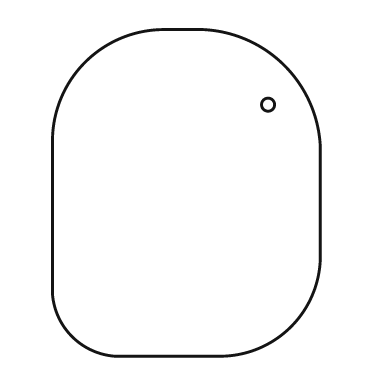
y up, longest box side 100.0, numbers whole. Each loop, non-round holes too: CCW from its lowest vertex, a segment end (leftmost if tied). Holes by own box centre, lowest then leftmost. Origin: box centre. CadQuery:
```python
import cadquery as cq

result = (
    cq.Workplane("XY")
    .moveTo(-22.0, -50.0)
    .lineTo(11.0, -50.0)
    .threePointArc((32.0, -41.0), (41.0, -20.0))
    .lineTo(41.0, 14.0)
    .threePointArc((30.0, 39.0), (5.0, 50.0))
    .lineTo(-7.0, 50.0)
    .threePointArc((-31.0, 40.0), (-41.0, 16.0))
    .lineTo(-41.0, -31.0)
    .threePointArc((-35.0, -44.0), (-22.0, -50.0))
    .close()
    .moveTo(25.0, 27.0)
    .circle(2.0)
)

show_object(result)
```